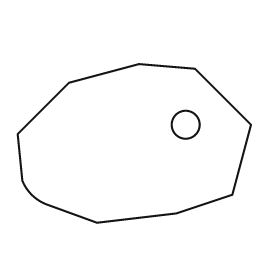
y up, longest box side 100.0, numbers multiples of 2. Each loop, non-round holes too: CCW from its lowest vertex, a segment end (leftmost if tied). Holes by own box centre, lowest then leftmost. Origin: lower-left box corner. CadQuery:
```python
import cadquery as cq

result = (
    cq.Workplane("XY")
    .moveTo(34.0, 0.0)
    .lineTo(68.0, 4.0)
    .lineTo(92.0, 12.0)
    .lineTo(100.0, 42.0)
    .lineTo(76.0, 66.0)
    .lineTo(52.0, 68.0)
    .lineTo(22.0, 60.0)
    .lineTo(0.0, 38.0)
    .lineTo(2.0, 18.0)
    .threePointArc((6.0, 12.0), (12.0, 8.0))
    .close()
    .moveTo(72.0, 42.0)
    .circle(6.0)
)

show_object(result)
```